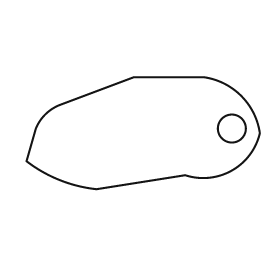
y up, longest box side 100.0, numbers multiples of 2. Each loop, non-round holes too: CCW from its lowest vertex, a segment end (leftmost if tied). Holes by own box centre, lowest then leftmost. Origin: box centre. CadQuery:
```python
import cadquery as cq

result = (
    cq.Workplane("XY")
    .moveTo(-20.0, -24.0)
    .lineTo(18.0, -18.0)
    .threePointArc((38.0, -16.0), (50.0, 0.0))
    .threePointArc((42.0, 16.0), (26.0, 24.0))
    .lineTo(-4.0, 24.0)
    .lineTo(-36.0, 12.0)
    .threePointArc((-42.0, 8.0), (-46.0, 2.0))
    .lineTo(-50.0, -12.0)
    .threePointArc((-36.0, -20.0), (-20.0, -24.0))
    .close()
    .moveTo(38.0, 2.0)
    .circle(6.0)
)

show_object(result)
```